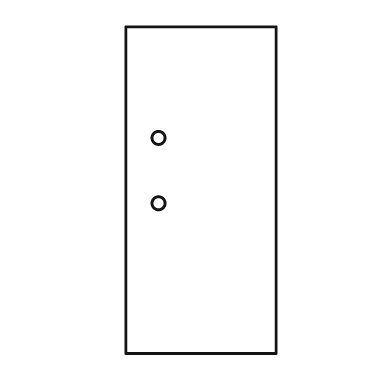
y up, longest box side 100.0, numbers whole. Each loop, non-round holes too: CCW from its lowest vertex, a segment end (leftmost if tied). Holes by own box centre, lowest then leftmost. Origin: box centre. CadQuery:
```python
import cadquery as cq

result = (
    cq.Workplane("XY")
    .moveTo(-23.0, -50.0)
    .lineTo(23.0, -50.0)
    .lineTo(23.0, 50.0)
    .lineTo(-23.0, 50.0)
    .close()
    .moveTo(-13.0, -4.0)
    .circle(2.0)
    .moveTo(-13.0, 16.0)
    .circle(2.0)
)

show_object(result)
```